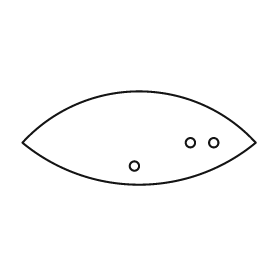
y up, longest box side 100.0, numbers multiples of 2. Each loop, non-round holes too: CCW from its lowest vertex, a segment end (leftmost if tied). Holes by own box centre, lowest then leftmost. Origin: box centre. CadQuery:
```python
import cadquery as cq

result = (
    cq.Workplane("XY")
    .moveTo(-50.0, -2.0)
    .threePointArc((0.0, -20.0), (50.0, -2.0))
    .threePointArc((0.0, 20.0), (-50.0, -2.0))
    .close()
    .moveTo(-2.0, -12.0)
    .circle(2.0)
    .moveTo(22.0, -2.0)
    .circle(2.0)
    .moveTo(32.0, -2.0)
    .circle(2.0)
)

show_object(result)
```